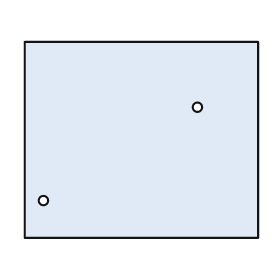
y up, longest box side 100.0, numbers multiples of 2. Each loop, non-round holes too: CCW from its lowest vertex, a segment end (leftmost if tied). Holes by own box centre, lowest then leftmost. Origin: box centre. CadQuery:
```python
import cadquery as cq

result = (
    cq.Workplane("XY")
    .moveTo(-50.0, -42.0)
    .lineTo(50.0, -42.0)
    .lineTo(50.0, 42.0)
    .lineTo(-50.0, 42.0)
    .close()
    .moveTo(-42.0, -26.0)
    .circle(2.0)
    .moveTo(24.0, 14.0)
    .circle(2.0)
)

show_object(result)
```